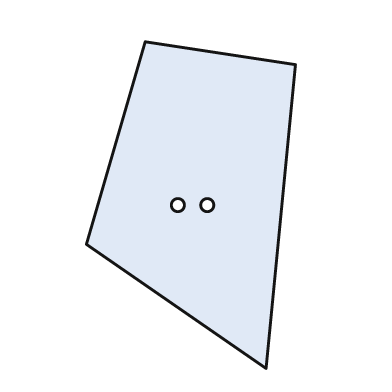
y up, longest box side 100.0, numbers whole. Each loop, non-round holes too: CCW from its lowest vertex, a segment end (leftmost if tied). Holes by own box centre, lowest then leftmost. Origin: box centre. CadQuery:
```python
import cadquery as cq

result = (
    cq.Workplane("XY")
    .moveTo(23.0, -50.0)
    .lineTo(32.0, 43.0)
    .lineTo(-14.0, 50.0)
    .lineTo(-32.0, -12.0)
    .close()
    .moveTo(-4.0, 0.0)
    .circle(2.0)
    .moveTo(5.0, 0.0)
    .circle(2.0)
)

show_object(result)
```